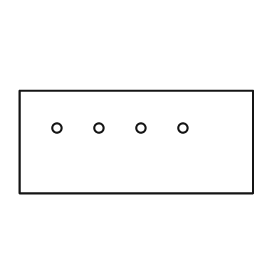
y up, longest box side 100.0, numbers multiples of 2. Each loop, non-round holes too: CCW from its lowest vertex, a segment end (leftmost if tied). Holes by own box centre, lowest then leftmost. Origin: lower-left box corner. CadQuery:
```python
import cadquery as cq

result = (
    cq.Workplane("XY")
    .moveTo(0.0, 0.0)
    .lineTo(100.0, 0.0)
    .lineTo(100.0, 44.0)
    .lineTo(0.0, 44.0)
    .close()
    .moveTo(16.0, 28.0)
    .circle(2.0)
    .moveTo(34.0, 28.0)
    .circle(2.0)
    .moveTo(52.0, 28.0)
    .circle(2.0)
    .moveTo(70.0, 28.0)
    .circle(2.0)
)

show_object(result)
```